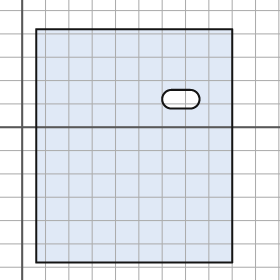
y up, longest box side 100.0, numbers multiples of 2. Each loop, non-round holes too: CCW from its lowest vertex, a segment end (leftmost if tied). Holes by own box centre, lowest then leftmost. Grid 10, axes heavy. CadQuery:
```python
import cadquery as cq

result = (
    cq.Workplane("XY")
    .moveTo(6.0, -58.0)
    .lineTo(90.0, -58.0)
    .lineTo(90.0, 42.0)
    .lineTo(6.0, 42.0)
    .close()
    .moveTo(64.0, 8.0)
    .lineTo(72.0, 8.0)
    .threePointArc((76.0, 12.0), (72.0, 16.0))
    .lineTo(64.0, 16.0)
    .threePointArc((60.0, 12.0), (64.0, 8.0))
    .close()
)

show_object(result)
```